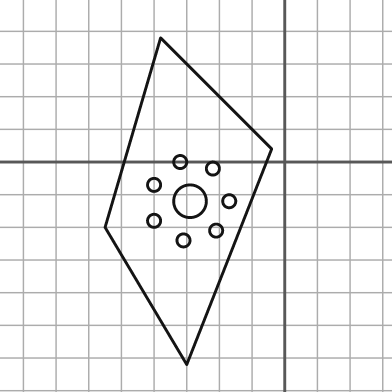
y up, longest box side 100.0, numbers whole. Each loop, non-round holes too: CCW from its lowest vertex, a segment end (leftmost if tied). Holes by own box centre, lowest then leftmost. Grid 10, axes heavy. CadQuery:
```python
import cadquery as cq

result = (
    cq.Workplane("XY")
    .moveTo(-30.0, -62.0)
    .lineTo(-4.0, 4.0)
    .lineTo(-38.0, 38.0)
    .lineTo(-55.0, -20.0)
    .close()
    .moveTo(-31.0, -24.0)
    .circle(2.0)
    .moveTo(-21.0, -21.0)
    .circle(2.0)
    .moveTo(-40.0, -18.0)
    .circle(2.0)
    .moveTo(-29.0, -12.0)
    .circle(5.0)
    .moveTo(-17.0, -12.0)
    .circle(2.0)
    .moveTo(-40.0, -7.0)
    .circle(2.0)
    .moveTo(-22.0, -2.0)
    .circle(2.0)
    .moveTo(-32.0, 0.0)
    .circle(2.0)
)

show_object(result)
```